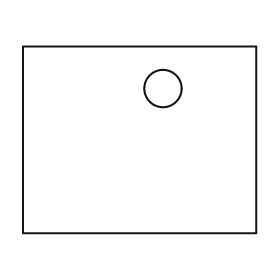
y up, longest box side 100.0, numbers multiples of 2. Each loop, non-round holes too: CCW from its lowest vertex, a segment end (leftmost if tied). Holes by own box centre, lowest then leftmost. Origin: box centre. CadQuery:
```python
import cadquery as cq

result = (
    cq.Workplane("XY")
    .moveTo(-50.0, -40.0)
    .lineTo(50.0, -40.0)
    .lineTo(50.0, 40.0)
    .lineTo(-50.0, 40.0)
    .close()
    .moveTo(10.0, 22.0)
    .circle(8.0)
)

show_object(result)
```